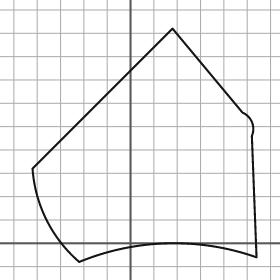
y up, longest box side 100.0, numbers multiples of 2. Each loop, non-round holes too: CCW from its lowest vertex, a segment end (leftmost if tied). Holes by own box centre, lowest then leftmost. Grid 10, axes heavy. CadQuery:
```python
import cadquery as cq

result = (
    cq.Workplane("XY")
    .moveTo(-22.0, -8.0)
    .threePointArc((16.0, 0.0), (54.0, -6.0))
    .lineTo(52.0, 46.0)
    .threePointArc((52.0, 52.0), (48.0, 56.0))
    .lineTo(18.0, 92.0)
    .lineTo(-42.0, 32.0)
    .threePointArc((-36.0, 10.0), (-22.0, -8.0))
    .close()
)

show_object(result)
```